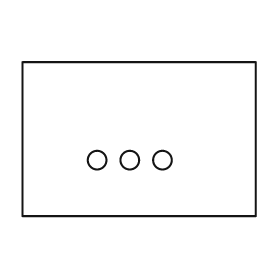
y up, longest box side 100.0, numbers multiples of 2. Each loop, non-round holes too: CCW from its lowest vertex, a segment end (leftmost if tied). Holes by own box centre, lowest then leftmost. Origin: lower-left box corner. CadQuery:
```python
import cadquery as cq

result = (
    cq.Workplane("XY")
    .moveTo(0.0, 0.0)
    .lineTo(100.0, 0.0)
    .lineTo(100.0, 66.0)
    .lineTo(0.0, 66.0)
    .close()
    .moveTo(32.0, 24.0)
    .circle(4.0)
    .moveTo(46.0, 24.0)
    .circle(4.0)
    .moveTo(60.0, 24.0)
    .circle(4.0)
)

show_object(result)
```